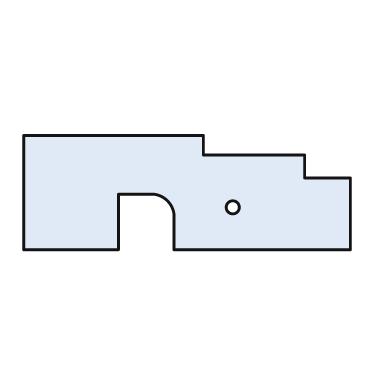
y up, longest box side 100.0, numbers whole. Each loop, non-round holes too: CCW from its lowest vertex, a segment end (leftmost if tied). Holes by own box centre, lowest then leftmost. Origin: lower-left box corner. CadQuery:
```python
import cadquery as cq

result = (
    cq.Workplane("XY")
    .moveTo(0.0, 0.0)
    .lineTo(29.0, 0.0)
    .lineTo(29.0, 17.0)
    .lineTo(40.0, 17.0)
    .threePointArc((44.0, 15.0), (46.0, 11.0))
    .lineTo(46.0, 0.0)
    .lineTo(100.0, 0.0)
    .lineTo(100.0, 22.0)
    .lineTo(86.0, 22.0)
    .lineTo(86.0, 29.0)
    .lineTo(55.0, 29.0)
    .lineTo(55.0, 35.0)
    .lineTo(0.0, 35.0)
    .close()
    .moveTo(64.0, 13.0)
    .circle(2.0)
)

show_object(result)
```